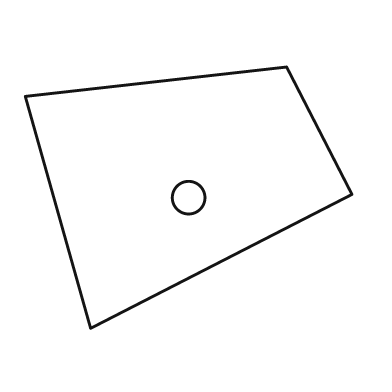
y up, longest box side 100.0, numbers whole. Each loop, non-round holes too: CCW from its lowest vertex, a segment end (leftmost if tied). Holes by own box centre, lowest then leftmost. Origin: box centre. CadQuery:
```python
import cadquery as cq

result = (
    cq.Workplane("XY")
    .moveTo(-30.0, -40.0)
    .lineTo(50.0, 1.0)
    .lineTo(30.0, 40.0)
    .lineTo(-50.0, 31.0)
    .close()
    .moveTo(0.0, 0.0)
    .circle(5.0)
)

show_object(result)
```